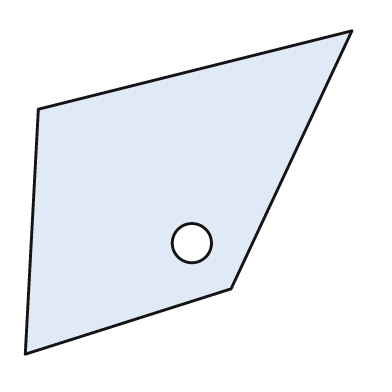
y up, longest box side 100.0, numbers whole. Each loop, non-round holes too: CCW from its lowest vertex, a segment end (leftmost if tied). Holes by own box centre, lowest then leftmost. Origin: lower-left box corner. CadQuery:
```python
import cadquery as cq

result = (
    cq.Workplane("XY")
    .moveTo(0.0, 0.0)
    .lineTo(63.0, 20.0)
    .lineTo(100.0, 99.0)
    .lineTo(4.0, 75.0)
    .close()
    .moveTo(51.0, 34.0)
    .circle(6.0)
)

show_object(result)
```